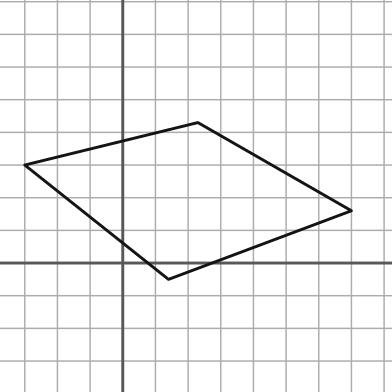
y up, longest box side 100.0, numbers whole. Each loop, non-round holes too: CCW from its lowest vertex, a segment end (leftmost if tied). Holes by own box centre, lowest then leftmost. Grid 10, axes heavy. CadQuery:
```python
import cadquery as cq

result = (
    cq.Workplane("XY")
    .moveTo(14.0, -5.0)
    .lineTo(70.0, 16.0)
    .lineTo(23.0, 43.0)
    .lineTo(-30.0, 30.0)
    .close()
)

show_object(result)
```